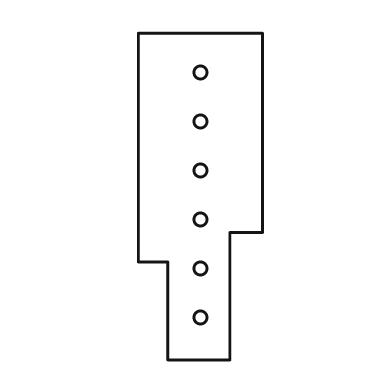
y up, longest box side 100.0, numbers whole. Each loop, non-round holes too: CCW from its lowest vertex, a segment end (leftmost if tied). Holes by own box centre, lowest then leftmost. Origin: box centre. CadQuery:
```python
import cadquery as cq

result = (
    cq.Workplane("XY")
    .moveTo(-10.0, -50.0)
    .lineTo(9.0, -50.0)
    .lineTo(9.0, -11.0)
    .lineTo(19.0, -11.0)
    .lineTo(19.0, 50.0)
    .lineTo(-19.0, 50.0)
    .lineTo(-19.0, -20.0)
    .lineTo(-10.0, -20.0)
    .close()
    .moveTo(0.0, -37.0)
    .circle(2.0)
    .moveTo(0.0, -22.0)
    .circle(2.0)
    .moveTo(0.0, -7.0)
    .circle(2.0)
    .moveTo(0.0, 8.0)
    .circle(2.0)
    .moveTo(0.0, 23.0)
    .circle(2.0)
    .moveTo(0.0, 38.0)
    .circle(2.0)
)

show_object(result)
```